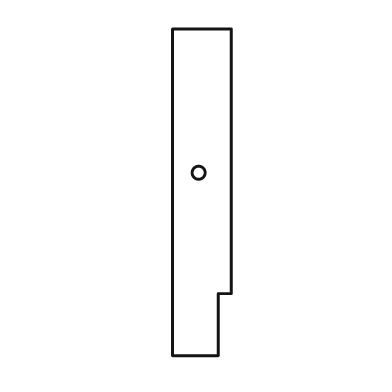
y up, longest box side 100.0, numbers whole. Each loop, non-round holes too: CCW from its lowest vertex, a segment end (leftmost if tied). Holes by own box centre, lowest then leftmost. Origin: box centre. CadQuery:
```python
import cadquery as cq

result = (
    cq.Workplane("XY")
    .moveTo(-9.0, -50.0)
    .lineTo(5.0, -50.0)
    .lineTo(5.0, -31.0)
    .lineTo(9.0, -31.0)
    .lineTo(9.0, 50.0)
    .lineTo(-9.0, 50.0)
    .close()
    .moveTo(-1.0, 6.0)
    .circle(2.0)
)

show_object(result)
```